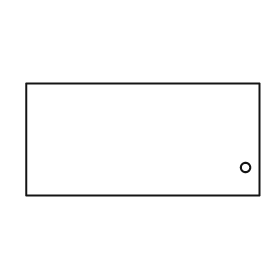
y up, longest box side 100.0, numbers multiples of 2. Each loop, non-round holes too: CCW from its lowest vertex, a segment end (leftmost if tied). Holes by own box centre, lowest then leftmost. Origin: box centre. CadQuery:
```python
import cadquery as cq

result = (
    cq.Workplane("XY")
    .moveTo(-50.0, -24.0)
    .lineTo(50.0, -24.0)
    .lineTo(50.0, 24.0)
    .lineTo(-50.0, 24.0)
    .close()
    .moveTo(44.0, -12.0)
    .circle(2.0)
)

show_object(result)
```